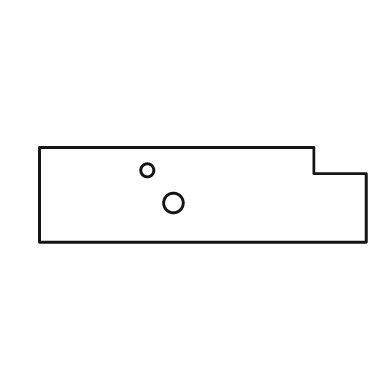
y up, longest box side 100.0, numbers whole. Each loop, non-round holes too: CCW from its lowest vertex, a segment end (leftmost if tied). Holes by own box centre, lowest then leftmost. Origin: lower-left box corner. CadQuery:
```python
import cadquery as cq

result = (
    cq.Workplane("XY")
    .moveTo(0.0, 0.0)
    .lineTo(100.0, 0.0)
    .lineTo(100.0, 21.0)
    .lineTo(84.0, 21.0)
    .lineTo(84.0, 29.0)
    .lineTo(0.0, 29.0)
    .close()
    .moveTo(41.0, 12.0)
    .circle(3.0)
    .moveTo(33.0, 22.0)
    .circle(2.0)
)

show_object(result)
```